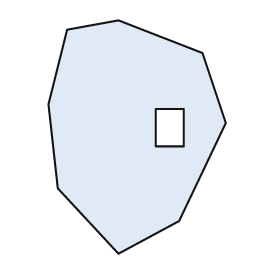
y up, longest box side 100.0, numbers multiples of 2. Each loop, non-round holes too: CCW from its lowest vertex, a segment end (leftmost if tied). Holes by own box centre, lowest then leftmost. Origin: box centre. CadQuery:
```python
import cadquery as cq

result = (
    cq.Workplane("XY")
    .moveTo(-8.0, -50.0)
    .lineTo(18.0, -36.0)
    .lineTo(38.0, 6.0)
    .lineTo(28.0, 36.0)
    .lineTo(-8.0, 50.0)
    .lineTo(-30.0, 46.0)
    .lineTo(-38.0, 14.0)
    .lineTo(-34.0, -22.0)
    .close()
    .moveTo(8.0, -4.0)
    .lineTo(20.0, -4.0)
    .lineTo(20.0, 12.0)
    .lineTo(8.0, 12.0)
    .close()
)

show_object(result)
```